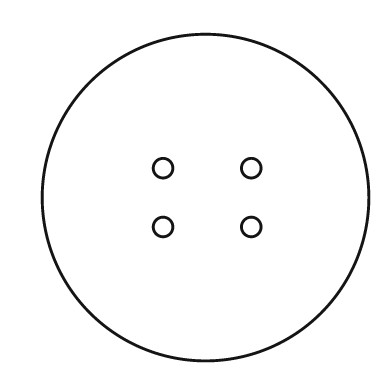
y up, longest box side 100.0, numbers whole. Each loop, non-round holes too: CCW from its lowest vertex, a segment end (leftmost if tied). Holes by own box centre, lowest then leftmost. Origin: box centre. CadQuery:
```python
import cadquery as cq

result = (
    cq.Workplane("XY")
    .moveTo(0.0, 0.0)
    .circle(50.0)
    .moveTo(-13.0, -9.0)
    .circle(3.0)
    .moveTo(14.0, -9.0)
    .circle(3.0)
    .moveTo(-13.0, 9.0)
    .circle(3.0)
    .moveTo(14.0, 9.0)
    .circle(3.0)
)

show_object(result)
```